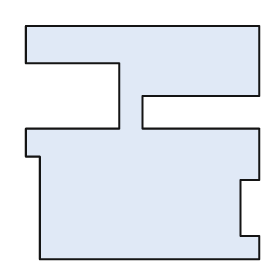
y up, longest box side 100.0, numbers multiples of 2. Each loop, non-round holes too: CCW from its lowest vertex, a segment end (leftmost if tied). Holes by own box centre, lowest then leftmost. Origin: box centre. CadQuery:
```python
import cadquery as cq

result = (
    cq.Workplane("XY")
    .moveTo(-44.0, -50.0)
    .lineTo(50.0, -50.0)
    .lineTo(50.0, -40.0)
    .lineTo(42.0, -40.0)
    .lineTo(42.0, -16.0)
    .lineTo(50.0, -16.0)
    .lineTo(50.0, 6.0)
    .lineTo(0.0, 6.0)
    .lineTo(0.0, 20.0)
    .lineTo(50.0, 20.0)
    .lineTo(50.0, 50.0)
    .lineTo(-50.0, 50.0)
    .lineTo(-50.0, 34.0)
    .lineTo(-10.0, 34.0)
    .lineTo(-10.0, 6.0)
    .lineTo(-50.0, 6.0)
    .lineTo(-50.0, -6.0)
    .lineTo(-44.0, -6.0)
    .close()
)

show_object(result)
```